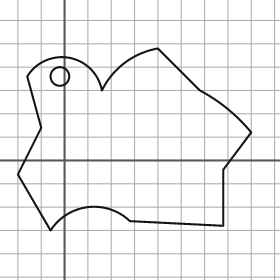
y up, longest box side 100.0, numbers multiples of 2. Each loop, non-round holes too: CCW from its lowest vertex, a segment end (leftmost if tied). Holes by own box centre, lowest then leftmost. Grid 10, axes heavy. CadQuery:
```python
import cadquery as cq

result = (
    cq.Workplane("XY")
    .moveTo(-6.0, -30.0)
    .threePointArc((10.0, -20.0), (28.0, -26.0))
    .lineTo(68.0, -28.0)
    .lineTo(68.0, -4.0)
    .lineTo(80.0, 12.0)
    .threePointArc((70.0, 22.0), (58.0, 30.0))
    .lineTo(40.0, 48.0)
    .threePointArc((26.0, 42.0), (16.0, 30.0))
    .threePointArc((2.0, 44.0), (-16.0, 36.0))
    .lineTo(-10.0, 14.0)
    .lineTo(-20.0, -6.0)
    .close()
    .moveTo(-2.0, 36.0)
    .circle(4.0)
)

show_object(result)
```